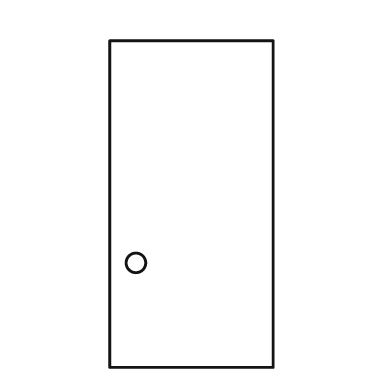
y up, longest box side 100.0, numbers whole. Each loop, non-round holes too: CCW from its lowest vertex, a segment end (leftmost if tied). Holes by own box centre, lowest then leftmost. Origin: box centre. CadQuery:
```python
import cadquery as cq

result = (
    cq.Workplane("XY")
    .moveTo(-25.0, -50.0)
    .lineTo(25.0, -50.0)
    .lineTo(25.0, 50.0)
    .lineTo(-25.0, 50.0)
    .close()
    .moveTo(-17.0, -18.0)
    .circle(3.0)
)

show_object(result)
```